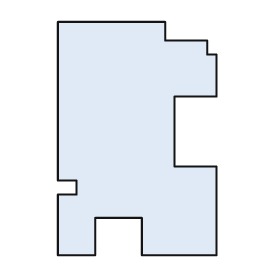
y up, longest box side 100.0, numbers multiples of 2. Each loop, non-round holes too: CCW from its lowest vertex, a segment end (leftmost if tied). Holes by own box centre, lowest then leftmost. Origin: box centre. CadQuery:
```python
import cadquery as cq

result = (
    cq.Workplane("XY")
    .moveTo(-34.0, -50.0)
    .lineTo(-18.0, -50.0)
    .lineTo(-18.0, -34.0)
    .lineTo(2.0, -34.0)
    .lineTo(2.0, -50.0)
    .lineTo(34.0, -50.0)
    .lineTo(34.0, -12.0)
    .lineTo(16.0, -12.0)
    .lineTo(16.0, 18.0)
    .lineTo(34.0, 18.0)
    .lineTo(34.0, 36.0)
    .lineTo(30.0, 36.0)
    .lineTo(30.0, 42.0)
    .lineTo(12.0, 42.0)
    .lineTo(12.0, 50.0)
    .lineTo(-34.0, 50.0)
    .lineTo(-34.0, -18.0)
    .lineTo(-26.0, -18.0)
    .lineTo(-26.0, -24.0)
    .lineTo(-34.0, -24.0)
    .close()
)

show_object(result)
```